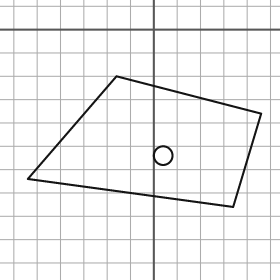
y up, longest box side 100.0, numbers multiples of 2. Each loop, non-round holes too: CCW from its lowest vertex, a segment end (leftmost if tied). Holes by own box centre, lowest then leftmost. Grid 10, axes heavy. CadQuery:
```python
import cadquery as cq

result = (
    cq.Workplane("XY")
    .moveTo(34.0, -76.0)
    .lineTo(46.0, -36.0)
    .lineTo(-16.0, -20.0)
    .lineTo(-54.0, -64.0)
    .close()
    .moveTo(4.0, -54.0)
    .circle(4.0)
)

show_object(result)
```